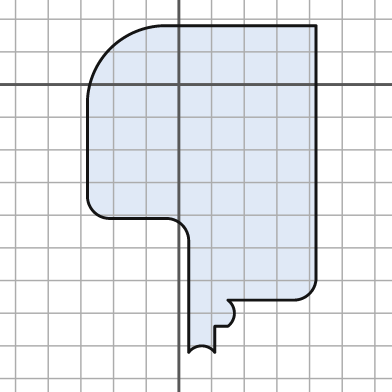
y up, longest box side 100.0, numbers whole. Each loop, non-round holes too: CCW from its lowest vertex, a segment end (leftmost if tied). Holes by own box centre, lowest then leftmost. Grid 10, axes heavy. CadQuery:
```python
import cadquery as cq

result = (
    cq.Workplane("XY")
    .moveTo(3.0, -82.0)
    .threePointArc((7.0, -80.0), (11.0, -82.0))
    .lineTo(11.0, -74.0)
    .lineTo(15.0, -74.0)
    .threePointArc((17.0, -70.0), (15.0, -66.0))
    .lineTo(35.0, -66.0)
    .threePointArc((40.0, -64.0), (42.0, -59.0))
    .lineTo(42.0, 18.0)
    .lineTo(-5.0, 18.0)
    .threePointArc((-21.0, 11.0), (-28.0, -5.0))
    .lineTo(-28.0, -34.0)
    .threePointArc((-26.0, -39.0), (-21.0, -41.0))
    .lineTo(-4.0, -41.0)
    .threePointArc((1.0, -43.0), (3.0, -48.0))
    .close()
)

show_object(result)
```